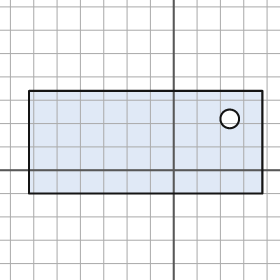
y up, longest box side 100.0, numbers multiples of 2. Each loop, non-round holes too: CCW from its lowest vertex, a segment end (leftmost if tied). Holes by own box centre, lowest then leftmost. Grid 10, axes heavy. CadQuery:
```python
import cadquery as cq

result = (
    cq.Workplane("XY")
    .moveTo(-62.0, -10.0)
    .lineTo(38.0, -10.0)
    .lineTo(38.0, 34.0)
    .lineTo(-62.0, 34.0)
    .close()
    .moveTo(24.0, 22.0)
    .circle(4.0)
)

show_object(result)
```